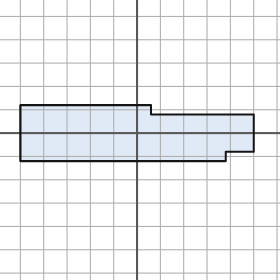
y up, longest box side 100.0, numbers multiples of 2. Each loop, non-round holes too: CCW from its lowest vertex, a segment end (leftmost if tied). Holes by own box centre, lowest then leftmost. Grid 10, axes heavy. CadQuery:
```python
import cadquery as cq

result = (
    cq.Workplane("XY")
    .moveTo(-50.0, -12.0)
    .lineTo(38.0, -12.0)
    .lineTo(38.0, -8.0)
    .lineTo(50.0, -8.0)
    .lineTo(50.0, 8.0)
    .lineTo(6.0, 8.0)
    .lineTo(6.0, 12.0)
    .lineTo(-50.0, 12.0)
    .close()
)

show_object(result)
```